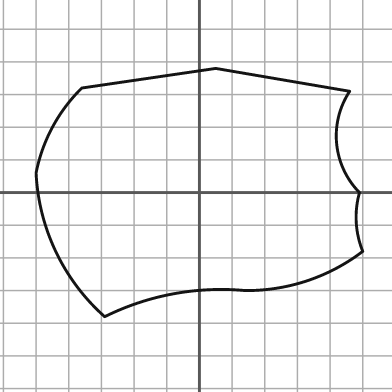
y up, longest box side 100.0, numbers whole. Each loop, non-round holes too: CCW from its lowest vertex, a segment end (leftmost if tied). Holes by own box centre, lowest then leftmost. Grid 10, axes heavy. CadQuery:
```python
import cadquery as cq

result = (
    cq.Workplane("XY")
    .moveTo(-29.0, -38.0)
    .threePointArc((-8.0, -31.0), (14.0, -30.0))
    .threePointArc((33.0, -27.0), (50.0, -18.0))
    .threePointArc((48.0, -9.0), (49.0, 0.0))
    .threePointArc((42.0, 15.0), (46.0, 31.0))
    .lineTo(5.0, 38.0)
    .lineTo(-36.0, 32.0)
    .threePointArc((-45.0, 20.0), (-50.0, 6.0))
    .threePointArc((-44.0, -18.0), (-29.0, -38.0))
    .close()
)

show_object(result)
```